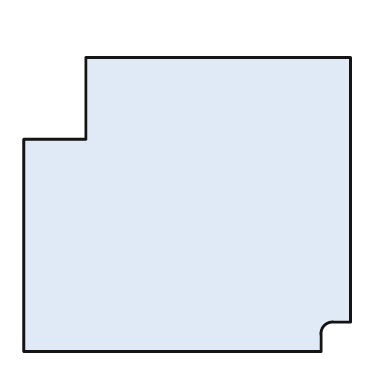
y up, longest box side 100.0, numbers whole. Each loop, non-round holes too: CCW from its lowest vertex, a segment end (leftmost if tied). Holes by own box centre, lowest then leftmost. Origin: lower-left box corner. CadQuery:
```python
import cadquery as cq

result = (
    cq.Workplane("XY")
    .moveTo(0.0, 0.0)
    .lineTo(91.0, 0.0)
    .lineTo(91.0, 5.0)
    .threePointArc((92.0, 8.0), (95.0, 9.0))
    .lineTo(100.0, 9.0)
    .lineTo(100.0, 90.0)
    .lineTo(19.0, 90.0)
    .lineTo(19.0, 65.0)
    .lineTo(0.0, 65.0)
    .close()
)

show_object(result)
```